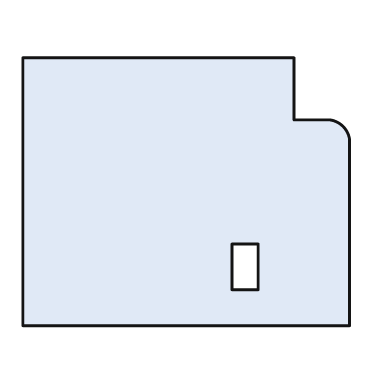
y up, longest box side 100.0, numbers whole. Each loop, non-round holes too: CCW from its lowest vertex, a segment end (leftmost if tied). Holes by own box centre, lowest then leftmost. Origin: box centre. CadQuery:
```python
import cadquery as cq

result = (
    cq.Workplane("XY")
    .moveTo(-50.0, -41.0)
    .lineTo(50.0, -41.0)
    .lineTo(50.0, 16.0)
    .threePointArc((48.0, 20.0), (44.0, 22.0))
    .lineTo(33.0, 22.0)
    .lineTo(33.0, 41.0)
    .lineTo(-50.0, 41.0)
    .close()
    .moveTo(14.0, -30.0)
    .lineTo(22.0, -30.0)
    .lineTo(22.0, -16.0)
    .lineTo(14.0, -16.0)
    .close()
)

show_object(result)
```